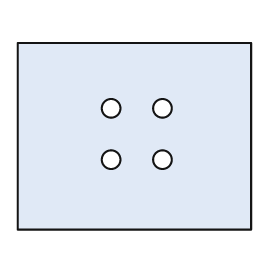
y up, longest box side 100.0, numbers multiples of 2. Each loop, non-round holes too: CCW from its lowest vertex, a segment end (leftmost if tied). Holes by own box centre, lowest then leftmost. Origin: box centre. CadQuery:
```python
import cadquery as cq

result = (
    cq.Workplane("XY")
    .moveTo(-50.0, -40.0)
    .lineTo(50.0, -40.0)
    .lineTo(50.0, 40.0)
    .lineTo(-50.0, 40.0)
    .close()
    .moveTo(-10.0, -10.0)
    .circle(4.0)
    .moveTo(12.0, -10.0)
    .circle(4.0)
    .moveTo(-10.0, 12.0)
    .circle(4.0)
    .moveTo(12.0, 12.0)
    .circle(4.0)
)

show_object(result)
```